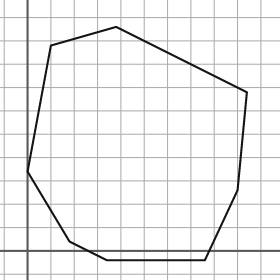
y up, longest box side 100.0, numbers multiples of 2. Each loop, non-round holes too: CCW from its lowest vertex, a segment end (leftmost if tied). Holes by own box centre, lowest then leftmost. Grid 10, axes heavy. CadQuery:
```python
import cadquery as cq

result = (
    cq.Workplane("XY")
    .moveTo(34.0, -4.0)
    .lineTo(76.0, -4.0)
    .lineTo(90.0, 26.0)
    .lineTo(94.0, 68.0)
    .lineTo(38.0, 96.0)
    .lineTo(10.0, 88.0)
    .lineTo(0.0, 34.0)
    .lineTo(18.0, 4.0)
    .close()
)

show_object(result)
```